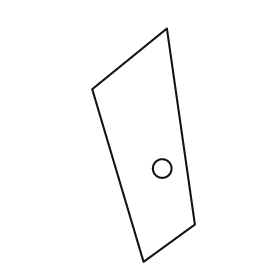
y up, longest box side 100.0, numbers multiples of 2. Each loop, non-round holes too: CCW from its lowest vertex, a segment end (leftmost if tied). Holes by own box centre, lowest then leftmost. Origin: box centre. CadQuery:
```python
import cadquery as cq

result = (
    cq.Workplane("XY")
    .moveTo(0.0, -50.0)
    .lineTo(22.0, -34.0)
    .lineTo(10.0, 50.0)
    .lineTo(-22.0, 24.0)
    .close()
    .moveTo(8.0, -10.0)
    .circle(4.0)
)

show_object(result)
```